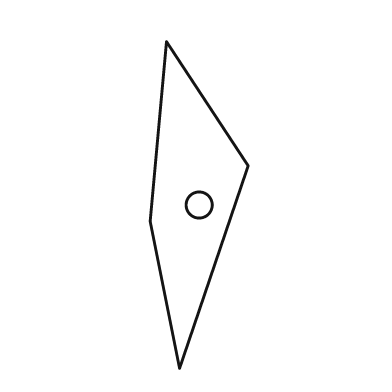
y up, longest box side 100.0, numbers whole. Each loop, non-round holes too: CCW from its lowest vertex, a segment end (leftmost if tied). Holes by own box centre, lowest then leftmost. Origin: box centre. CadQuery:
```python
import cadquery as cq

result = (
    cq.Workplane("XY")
    .moveTo(-6.0, -50.0)
    .lineTo(15.0, 12.0)
    .lineTo(-10.0, 50.0)
    .lineTo(-15.0, -5.0)
    .close()
    .moveTo(0.0, 0.0)
    .circle(4.0)
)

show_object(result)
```